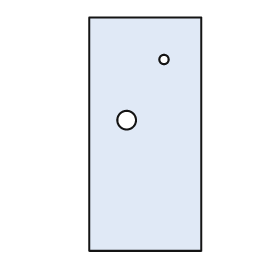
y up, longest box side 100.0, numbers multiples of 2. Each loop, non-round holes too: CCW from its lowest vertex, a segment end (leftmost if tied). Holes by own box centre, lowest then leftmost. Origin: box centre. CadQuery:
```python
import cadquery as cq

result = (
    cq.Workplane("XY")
    .moveTo(-24.0, -50.0)
    .lineTo(24.0, -50.0)
    .lineTo(24.0, 50.0)
    .lineTo(-24.0, 50.0)
    .close()
    .moveTo(-8.0, 6.0)
    .circle(4.0)
    .moveTo(8.0, 32.0)
    .circle(2.0)
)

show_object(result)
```